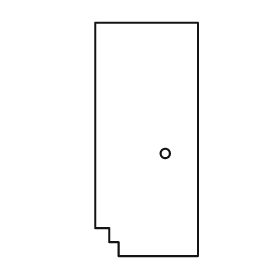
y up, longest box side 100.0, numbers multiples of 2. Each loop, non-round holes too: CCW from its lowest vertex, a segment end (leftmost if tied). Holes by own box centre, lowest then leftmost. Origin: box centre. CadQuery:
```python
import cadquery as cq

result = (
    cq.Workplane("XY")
    .moveTo(-12.0, -50.0)
    .lineTo(22.0, -50.0)
    .lineTo(22.0, 50.0)
    .lineTo(-22.0, 50.0)
    .lineTo(-22.0, -38.0)
    .lineTo(-16.0, -38.0)
    .lineTo(-16.0, -44.0)
    .lineTo(-12.0, -44.0)
    .close()
    .moveTo(8.0, -6.0)
    .circle(2.0)
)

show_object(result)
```